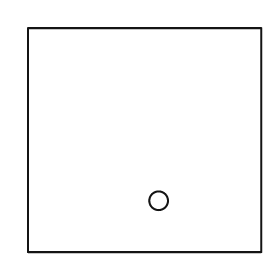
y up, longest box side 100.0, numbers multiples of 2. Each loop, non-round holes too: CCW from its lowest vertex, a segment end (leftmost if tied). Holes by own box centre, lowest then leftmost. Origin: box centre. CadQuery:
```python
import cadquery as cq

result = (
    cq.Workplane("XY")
    .moveTo(-50.0, -48.0)
    .lineTo(50.0, -48.0)
    .lineTo(50.0, 48.0)
    .lineTo(-50.0, 48.0)
    .close()
    .moveTo(6.0, -26.0)
    .circle(4.0)
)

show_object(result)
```